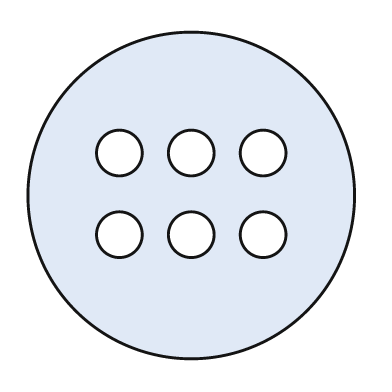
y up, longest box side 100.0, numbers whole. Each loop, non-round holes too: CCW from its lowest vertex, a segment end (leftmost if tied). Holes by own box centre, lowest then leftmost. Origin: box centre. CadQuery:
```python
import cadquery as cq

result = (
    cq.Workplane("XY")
    .moveTo(0.0, 0.0)
    .circle(50.0)
    .moveTo(-22.0, -12.0)
    .circle(7.0)
    .moveTo(0.0, -12.0)
    .circle(7.0)
    .moveTo(22.0, -12.0)
    .circle(7.0)
    .moveTo(-22.0, 13.0)
    .circle(7.0)
    .moveTo(0.0, 13.0)
    .circle(7.0)
    .moveTo(22.0, 13.0)
    .circle(7.0)
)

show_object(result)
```